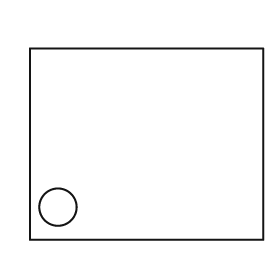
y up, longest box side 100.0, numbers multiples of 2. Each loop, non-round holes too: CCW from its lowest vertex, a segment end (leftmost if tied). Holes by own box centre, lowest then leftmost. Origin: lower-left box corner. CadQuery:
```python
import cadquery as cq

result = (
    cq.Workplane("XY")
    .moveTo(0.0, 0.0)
    .lineTo(100.0, 0.0)
    .lineTo(100.0, 82.0)
    .lineTo(0.0, 82.0)
    .close()
    .moveTo(12.0, 14.0)
    .circle(8.0)
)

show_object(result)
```